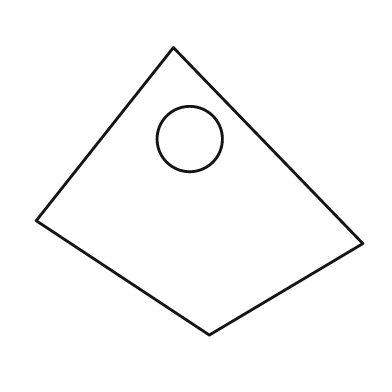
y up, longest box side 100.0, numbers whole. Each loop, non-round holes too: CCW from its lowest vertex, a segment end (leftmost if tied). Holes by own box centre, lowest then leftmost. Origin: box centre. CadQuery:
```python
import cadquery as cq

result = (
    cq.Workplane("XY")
    .moveTo(3.0, -44.0)
    .lineTo(50.0, -16.0)
    .lineTo(-8.0, 44.0)
    .lineTo(-50.0, -9.0)
    .close()
    .moveTo(-3.0, 16.0)
    .circle(10.0)
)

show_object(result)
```